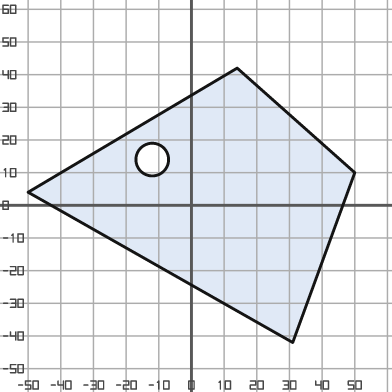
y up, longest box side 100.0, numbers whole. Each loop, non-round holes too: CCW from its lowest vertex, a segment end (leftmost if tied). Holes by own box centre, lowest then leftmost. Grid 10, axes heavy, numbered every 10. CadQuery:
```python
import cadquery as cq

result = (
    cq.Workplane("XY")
    .moveTo(31.0, -42.0)
    .lineTo(50.0, 10.0)
    .lineTo(14.0, 42.0)
    .lineTo(-50.0, 4.0)
    .close()
    .moveTo(-12.0, 14.0)
    .circle(5.0)
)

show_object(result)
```